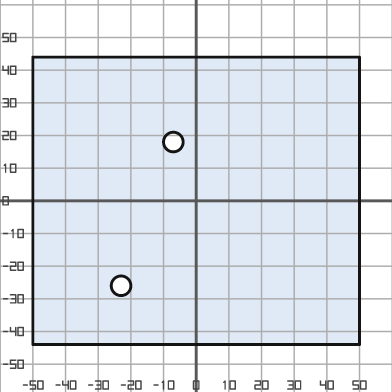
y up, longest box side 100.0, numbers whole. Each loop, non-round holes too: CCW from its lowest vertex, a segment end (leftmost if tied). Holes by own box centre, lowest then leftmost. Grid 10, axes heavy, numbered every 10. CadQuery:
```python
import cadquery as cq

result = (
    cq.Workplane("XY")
    .moveTo(-50.0, -44.0)
    .lineTo(50.0, -44.0)
    .lineTo(50.0, 44.0)
    .lineTo(-50.0, 44.0)
    .close()
    .moveTo(-23.0, -26.0)
    .circle(3.0)
    .moveTo(-7.0, 18.0)
    .circle(3.0)
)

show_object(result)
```